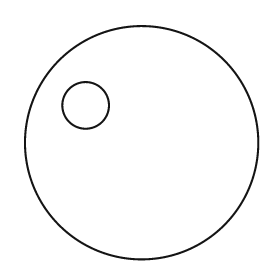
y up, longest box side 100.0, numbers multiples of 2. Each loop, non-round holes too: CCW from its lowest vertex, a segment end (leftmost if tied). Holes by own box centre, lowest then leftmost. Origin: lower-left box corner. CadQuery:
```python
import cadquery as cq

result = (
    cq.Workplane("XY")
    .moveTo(50.0, 50.0)
    .circle(50.0)
    .moveTo(26.0, 66.0)
    .circle(10.0)
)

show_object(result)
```